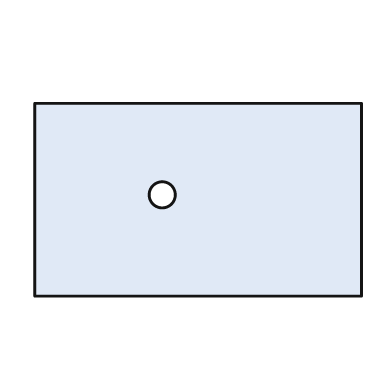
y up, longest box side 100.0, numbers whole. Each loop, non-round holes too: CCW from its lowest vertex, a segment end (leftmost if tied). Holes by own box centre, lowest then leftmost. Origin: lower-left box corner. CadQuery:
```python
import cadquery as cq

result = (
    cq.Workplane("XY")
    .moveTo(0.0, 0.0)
    .lineTo(100.0, 0.0)
    .lineTo(100.0, 59.0)
    .lineTo(0.0, 59.0)
    .close()
    .moveTo(39.0, 31.0)
    .circle(4.0)
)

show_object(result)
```